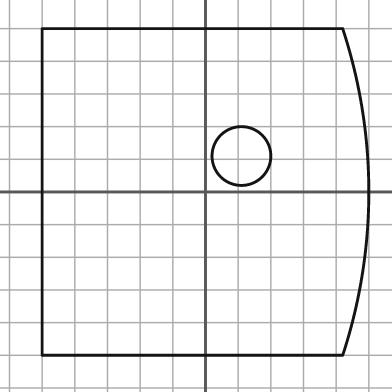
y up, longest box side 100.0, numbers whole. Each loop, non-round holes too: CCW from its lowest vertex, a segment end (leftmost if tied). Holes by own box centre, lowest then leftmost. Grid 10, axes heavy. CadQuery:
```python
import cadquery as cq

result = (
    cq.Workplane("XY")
    .moveTo(-50.0, -50.0)
    .lineTo(42.0, -50.0)
    .threePointArc((50.0, 0.0), (42.0, 50.0))
    .lineTo(-50.0, 50.0)
    .close()
    .moveTo(11.0, 11.0)
    .circle(9.0)
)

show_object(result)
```